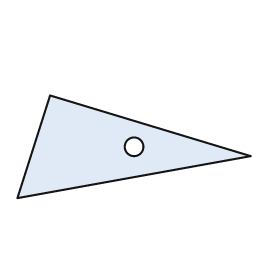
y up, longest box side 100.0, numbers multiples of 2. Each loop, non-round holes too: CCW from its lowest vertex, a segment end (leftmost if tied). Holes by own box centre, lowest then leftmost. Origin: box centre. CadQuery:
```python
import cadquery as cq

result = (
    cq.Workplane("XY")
    .moveTo(-50.0, -22.0)
    .lineTo(50.0, -4.0)
    .lineTo(-36.0, 22.0)
    .close()
    .moveTo(0.0, 0.0)
    .circle(4.0)
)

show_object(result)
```